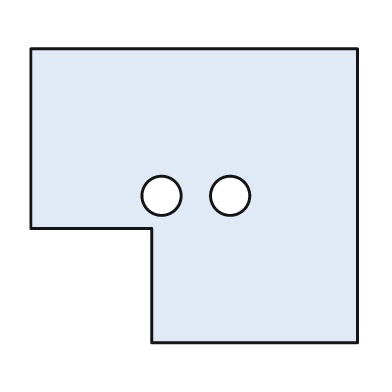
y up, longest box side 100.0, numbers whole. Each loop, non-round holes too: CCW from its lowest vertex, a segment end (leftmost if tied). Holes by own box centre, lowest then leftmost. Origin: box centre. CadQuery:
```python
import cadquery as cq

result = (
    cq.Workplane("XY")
    .moveTo(-13.0, -45.0)
    .lineTo(50.0, -45.0)
    .lineTo(50.0, 45.0)
    .lineTo(-50.0, 45.0)
    .lineTo(-50.0, -10.0)
    .lineTo(-13.0, -10.0)
    .close()
    .moveTo(-10.0, 0.0)
    .circle(6.0)
    .moveTo(11.0, 0.0)
    .circle(6.0)
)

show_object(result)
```